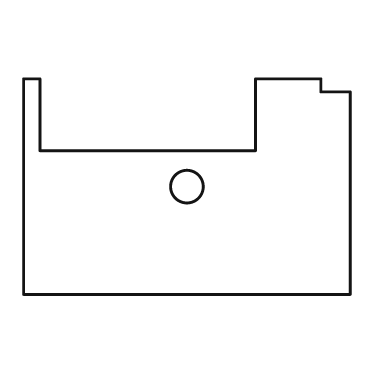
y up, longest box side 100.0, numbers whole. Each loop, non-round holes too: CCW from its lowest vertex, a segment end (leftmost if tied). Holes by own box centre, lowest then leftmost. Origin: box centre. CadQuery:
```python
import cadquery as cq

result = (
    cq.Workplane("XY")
    .moveTo(-50.0, -33.0)
    .lineTo(50.0, -33.0)
    .lineTo(50.0, 29.0)
    .lineTo(41.0, 29.0)
    .lineTo(41.0, 33.0)
    .lineTo(21.0, 33.0)
    .lineTo(21.0, 11.0)
    .lineTo(-45.0, 11.0)
    .lineTo(-45.0, 33.0)
    .lineTo(-50.0, 33.0)
    .close()
    .moveTo(0.0, 0.0)
    .circle(5.0)
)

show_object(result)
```